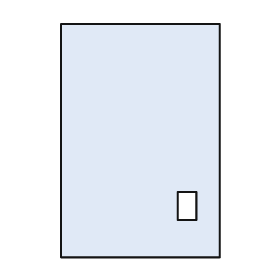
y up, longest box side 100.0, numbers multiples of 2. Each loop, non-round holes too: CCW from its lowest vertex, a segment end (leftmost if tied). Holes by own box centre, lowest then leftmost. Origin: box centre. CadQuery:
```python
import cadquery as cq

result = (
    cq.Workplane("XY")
    .moveTo(-34.0, -50.0)
    .lineTo(34.0, -50.0)
    .lineTo(34.0, 50.0)
    .lineTo(-34.0, 50.0)
    .close()
    .moveTo(16.0, -34.0)
    .lineTo(24.0, -34.0)
    .lineTo(24.0, -22.0)
    .lineTo(16.0, -22.0)
    .close()
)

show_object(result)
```